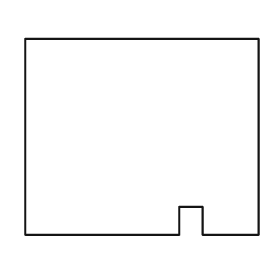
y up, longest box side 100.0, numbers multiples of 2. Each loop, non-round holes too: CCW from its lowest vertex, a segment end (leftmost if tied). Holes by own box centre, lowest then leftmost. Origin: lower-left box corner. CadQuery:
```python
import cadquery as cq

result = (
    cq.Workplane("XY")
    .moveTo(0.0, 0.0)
    .lineTo(66.0, 0.0)
    .lineTo(66.0, 12.0)
    .lineTo(76.0, 12.0)
    .lineTo(76.0, 0.0)
    .lineTo(100.0, 0.0)
    .lineTo(100.0, 84.0)
    .lineTo(0.0, 84.0)
    .close()
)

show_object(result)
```